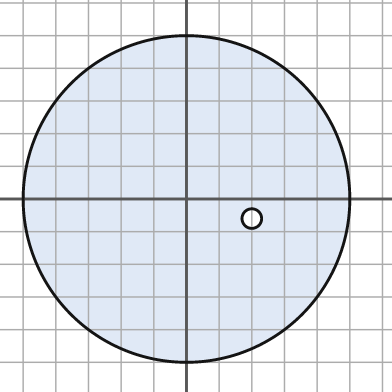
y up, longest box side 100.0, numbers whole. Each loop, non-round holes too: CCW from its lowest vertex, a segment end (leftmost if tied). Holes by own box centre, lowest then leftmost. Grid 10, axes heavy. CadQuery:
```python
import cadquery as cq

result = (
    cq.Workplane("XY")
    .moveTo(0.0, 0.0)
    .circle(50.0)
    .moveTo(20.0, -6.0)
    .circle(3.0)
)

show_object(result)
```